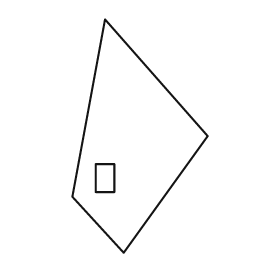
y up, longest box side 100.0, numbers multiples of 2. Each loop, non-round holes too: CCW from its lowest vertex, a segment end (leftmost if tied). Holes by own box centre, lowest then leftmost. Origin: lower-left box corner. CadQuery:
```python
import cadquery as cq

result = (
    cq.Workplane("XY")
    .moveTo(22.0, 0.0)
    .lineTo(58.0, 50.0)
    .lineTo(14.0, 100.0)
    .lineTo(0.0, 24.0)
    .close()
    .moveTo(10.0, 26.0)
    .lineTo(18.0, 26.0)
    .lineTo(18.0, 38.0)
    .lineTo(10.0, 38.0)
    .close()
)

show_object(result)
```